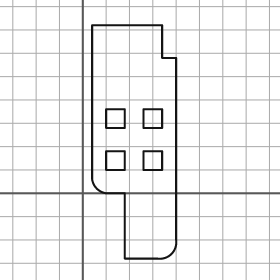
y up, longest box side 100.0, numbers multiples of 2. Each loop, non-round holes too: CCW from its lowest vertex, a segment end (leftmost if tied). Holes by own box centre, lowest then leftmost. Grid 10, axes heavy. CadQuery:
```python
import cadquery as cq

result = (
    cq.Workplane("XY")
    .moveTo(18.0, -28.0)
    .lineTo(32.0, -28.0)
    .threePointArc((38.0, -26.0), (40.0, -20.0))
    .lineTo(40.0, 58.0)
    .lineTo(34.0, 58.0)
    .lineTo(34.0, 72.0)
    .lineTo(4.0, 72.0)
    .lineTo(4.0, 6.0)
    .threePointArc((6.0, 2.0), (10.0, 0.0))
    .lineTo(18.0, 0.0)
    .close()
    .moveTo(10.0, 10.0)
    .lineTo(18.0, 10.0)
    .lineTo(18.0, 18.0)
    .lineTo(10.0, 18.0)
    .close()
    .moveTo(26.0, 10.0)
    .lineTo(34.0, 10.0)
    .lineTo(34.0, 18.0)
    .lineTo(26.0, 18.0)
    .close()
    .moveTo(10.0, 28.0)
    .lineTo(18.0, 28.0)
    .lineTo(18.0, 36.0)
    .lineTo(10.0, 36.0)
    .close()
    .moveTo(26.0, 28.0)
    .lineTo(34.0, 28.0)
    .lineTo(34.0, 36.0)
    .lineTo(26.0, 36.0)
    .close()
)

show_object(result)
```